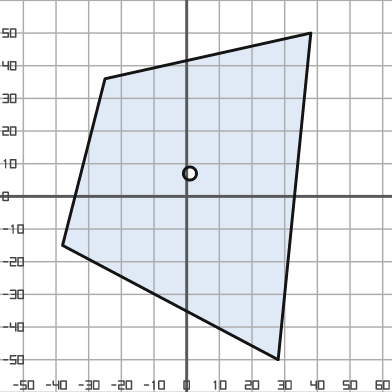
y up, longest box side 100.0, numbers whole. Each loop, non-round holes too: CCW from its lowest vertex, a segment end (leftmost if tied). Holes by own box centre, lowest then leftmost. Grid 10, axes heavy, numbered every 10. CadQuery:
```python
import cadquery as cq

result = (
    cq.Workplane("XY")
    .moveTo(28.0, -50.0)
    .lineTo(38.0, 50.0)
    .lineTo(-25.0, 36.0)
    .lineTo(-38.0, -15.0)
    .close()
    .moveTo(1.0, 7.0)
    .circle(2.0)
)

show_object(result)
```